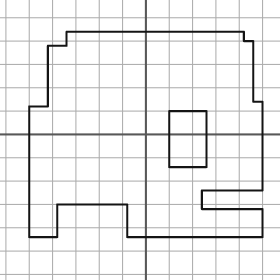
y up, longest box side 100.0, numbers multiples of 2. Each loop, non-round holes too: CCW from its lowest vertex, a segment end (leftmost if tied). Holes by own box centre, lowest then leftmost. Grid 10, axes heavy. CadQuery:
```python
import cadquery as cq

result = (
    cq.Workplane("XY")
    .moveTo(-50.0, -44.0)
    .lineTo(-38.0, -44.0)
    .lineTo(-38.0, -30.0)
    .lineTo(-8.0, -30.0)
    .lineTo(-8.0, -44.0)
    .lineTo(50.0, -44.0)
    .lineTo(50.0, -32.0)
    .lineTo(24.0, -32.0)
    .lineTo(24.0, -24.0)
    .lineTo(50.0, -24.0)
    .lineTo(50.0, 14.0)
    .lineTo(46.0, 14.0)
    .lineTo(46.0, 40.0)
    .lineTo(42.0, 40.0)
    .lineTo(42.0, 44.0)
    .lineTo(-34.0, 44.0)
    .lineTo(-34.0, 38.0)
    .lineTo(-42.0, 38.0)
    .lineTo(-42.0, 12.0)
    .lineTo(-50.0, 12.0)
    .close()
    .moveTo(10.0, -14.0)
    .lineTo(26.0, -14.0)
    .lineTo(26.0, 10.0)
    .lineTo(10.0, 10.0)
    .close()
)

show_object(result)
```